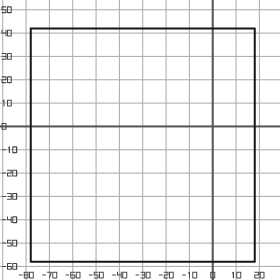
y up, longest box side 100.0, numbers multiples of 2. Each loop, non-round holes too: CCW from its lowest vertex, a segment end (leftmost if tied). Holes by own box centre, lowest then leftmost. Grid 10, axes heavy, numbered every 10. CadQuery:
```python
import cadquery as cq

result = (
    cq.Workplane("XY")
    .moveTo(-78.0, -58.0)
    .lineTo(18.0, -58.0)
    .lineTo(18.0, 42.0)
    .lineTo(-78.0, 42.0)
    .close()
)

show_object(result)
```